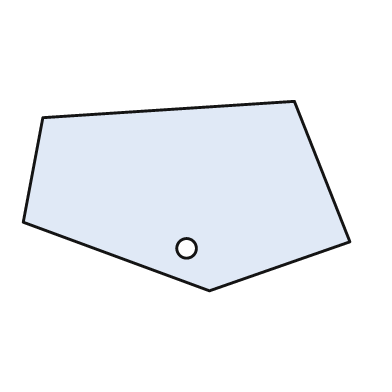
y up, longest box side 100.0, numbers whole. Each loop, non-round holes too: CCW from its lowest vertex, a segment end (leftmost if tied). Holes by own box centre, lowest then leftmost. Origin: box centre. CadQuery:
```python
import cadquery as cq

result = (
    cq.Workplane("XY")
    .moveTo(7.0, -29.0)
    .lineTo(50.0, -14.0)
    .lineTo(33.0, 29.0)
    .lineTo(-44.0, 24.0)
    .lineTo(-50.0, -8.0)
    .close()
    .moveTo(0.0, -16.0)
    .circle(3.0)
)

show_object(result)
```